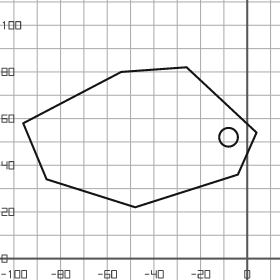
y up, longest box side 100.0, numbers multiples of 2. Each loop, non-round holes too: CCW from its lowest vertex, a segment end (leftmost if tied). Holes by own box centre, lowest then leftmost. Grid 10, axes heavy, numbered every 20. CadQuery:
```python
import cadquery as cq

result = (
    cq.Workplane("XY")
    .moveTo(-48.0, 22.0)
    .lineTo(-4.0, 36.0)
    .lineTo(4.0, 54.0)
    .lineTo(-26.0, 82.0)
    .lineTo(-54.0, 80.0)
    .lineTo(-96.0, 58.0)
    .lineTo(-86.0, 34.0)
    .close()
    .moveTo(-8.0, 52.0)
    .circle(4.0)
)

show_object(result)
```